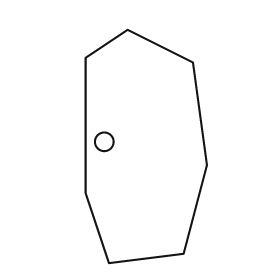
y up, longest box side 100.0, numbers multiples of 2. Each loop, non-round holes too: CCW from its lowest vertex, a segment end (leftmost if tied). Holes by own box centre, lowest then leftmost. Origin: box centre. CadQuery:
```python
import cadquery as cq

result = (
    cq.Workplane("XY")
    .moveTo(-16.0, -50.0)
    .lineTo(16.0, -46.0)
    .lineTo(26.0, -8.0)
    .lineTo(20.0, 36.0)
    .lineTo(-8.0, 50.0)
    .lineTo(-26.0, 38.0)
    .lineTo(-26.0, -20.0)
    .close()
    .moveTo(-18.0, 2.0)
    .circle(4.0)
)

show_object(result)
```